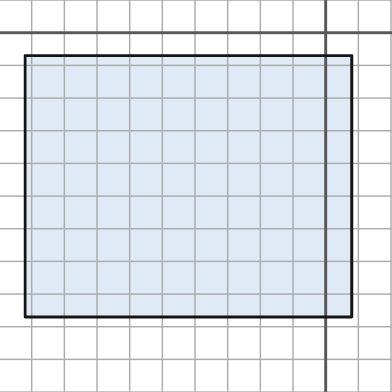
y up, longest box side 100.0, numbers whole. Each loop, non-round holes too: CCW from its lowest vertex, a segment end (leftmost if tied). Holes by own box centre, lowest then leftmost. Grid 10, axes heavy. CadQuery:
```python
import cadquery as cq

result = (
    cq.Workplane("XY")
    .moveTo(-92.0, -87.0)
    .lineTo(8.0, -87.0)
    .lineTo(8.0, -7.0)
    .lineTo(-92.0, -7.0)
    .close()
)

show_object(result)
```